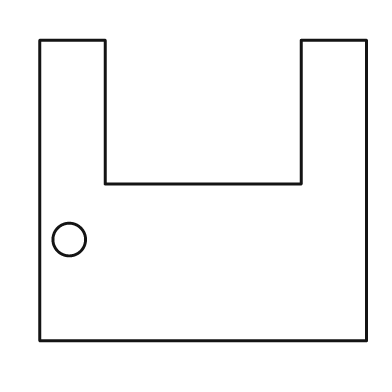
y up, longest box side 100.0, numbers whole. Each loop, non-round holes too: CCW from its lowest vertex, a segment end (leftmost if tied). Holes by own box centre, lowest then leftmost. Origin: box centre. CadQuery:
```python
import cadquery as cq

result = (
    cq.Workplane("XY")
    .moveTo(-50.0, -46.0)
    .lineTo(50.0, -46.0)
    .lineTo(50.0, 46.0)
    .lineTo(30.0, 46.0)
    .lineTo(30.0, 2.0)
    .lineTo(-30.0, 2.0)
    .lineTo(-30.0, 46.0)
    .lineTo(-50.0, 46.0)
    .close()
    .moveTo(-41.0, -15.0)
    .circle(5.0)
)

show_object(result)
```